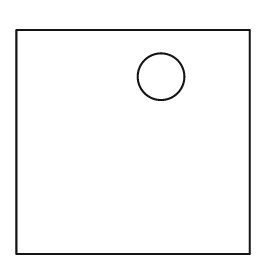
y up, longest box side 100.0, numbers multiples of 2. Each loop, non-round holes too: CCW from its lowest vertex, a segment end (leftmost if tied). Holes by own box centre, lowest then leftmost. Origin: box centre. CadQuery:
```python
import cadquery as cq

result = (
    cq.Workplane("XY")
    .moveTo(-50.0, -48.0)
    .lineTo(50.0, -48.0)
    .lineTo(50.0, 48.0)
    .lineTo(-50.0, 48.0)
    .close()
    .moveTo(12.0, 28.0)
    .circle(10.0)
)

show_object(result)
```